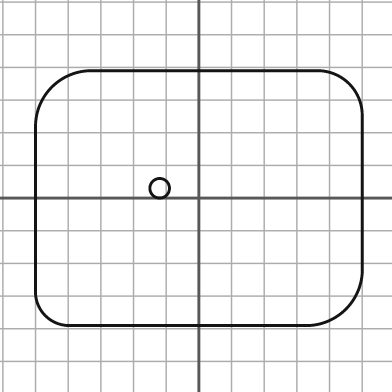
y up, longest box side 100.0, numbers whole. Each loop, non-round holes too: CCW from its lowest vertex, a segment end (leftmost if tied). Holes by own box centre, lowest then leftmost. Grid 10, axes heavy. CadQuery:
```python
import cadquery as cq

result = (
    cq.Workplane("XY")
    .moveTo(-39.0, -39.0)
    .lineTo(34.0, -39.0)
    .threePointArc((45.0, -34.0), (50.0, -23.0))
    .lineTo(50.0, 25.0)
    .threePointArc((46.0, 35.0), (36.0, 39.0))
    .lineTo(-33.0, 39.0)
    .threePointArc((-45.0, 34.0), (-50.0, 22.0))
    .lineTo(-50.0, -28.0)
    .threePointArc((-47.0, -36.0), (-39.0, -39.0))
    .close()
    .moveTo(-12.0, 3.0)
    .circle(3.0)
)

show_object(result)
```